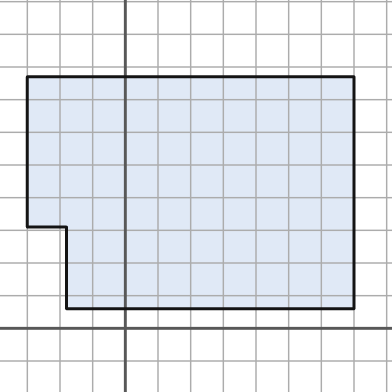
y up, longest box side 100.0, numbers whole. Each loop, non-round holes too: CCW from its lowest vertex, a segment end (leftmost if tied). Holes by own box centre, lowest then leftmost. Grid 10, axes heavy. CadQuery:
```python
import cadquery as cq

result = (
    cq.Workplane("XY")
    .moveTo(-18.0, 6.0)
    .lineTo(70.0, 6.0)
    .lineTo(70.0, 77.0)
    .lineTo(-30.0, 77.0)
    .lineTo(-30.0, 31.0)
    .lineTo(-18.0, 31.0)
    .close()
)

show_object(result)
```